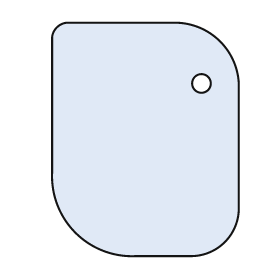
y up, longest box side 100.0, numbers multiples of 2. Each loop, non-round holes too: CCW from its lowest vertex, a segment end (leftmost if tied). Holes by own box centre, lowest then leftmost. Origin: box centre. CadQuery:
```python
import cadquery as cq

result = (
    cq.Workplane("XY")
    .moveTo(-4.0, -50.0)
    .lineTo(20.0, -50.0)
    .threePointArc((34.0, -44.0), (40.0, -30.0))
    .lineTo(40.0, 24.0)
    .threePointArc((32.0, 42.0), (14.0, 50.0))
    .lineTo(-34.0, 50.0)
    .threePointArc((-38.0, 48.0), (-40.0, 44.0))
    .lineTo(-40.0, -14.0)
    .threePointArc((-30.0, -40.0), (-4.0, -50.0))
    .close()
    .moveTo(24.0, 24.0)
    .circle(4.0)
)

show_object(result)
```